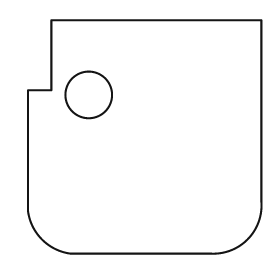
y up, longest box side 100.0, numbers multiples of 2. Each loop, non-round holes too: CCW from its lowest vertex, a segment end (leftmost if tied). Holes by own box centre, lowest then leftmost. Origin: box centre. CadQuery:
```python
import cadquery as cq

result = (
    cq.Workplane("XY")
    .moveTo(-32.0, -50.0)
    .lineTo(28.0, -50.0)
    .threePointArc((44.0, -44.0), (50.0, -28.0))
    .lineTo(50.0, 50.0)
    .lineTo(-40.0, 50.0)
    .lineTo(-40.0, 20.0)
    .lineTo(-50.0, 20.0)
    .lineTo(-50.0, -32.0)
    .threePointArc((-44.0, -44.0), (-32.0, -50.0))
    .close()
    .moveTo(-24.0, 18.0)
    .circle(10.0)
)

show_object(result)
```